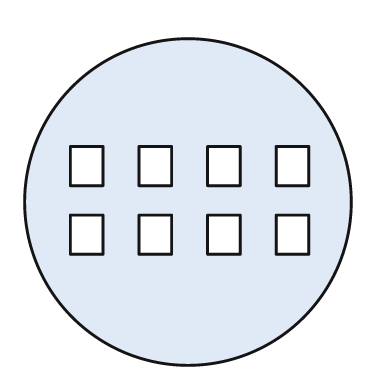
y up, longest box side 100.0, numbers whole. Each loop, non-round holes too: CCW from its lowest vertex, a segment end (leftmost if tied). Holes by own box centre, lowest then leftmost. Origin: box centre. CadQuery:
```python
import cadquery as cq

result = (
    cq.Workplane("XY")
    .moveTo(0.0, 0.0)
    .circle(50.0)
    .moveTo(-36.0, -16.0)
    .lineTo(-26.0, -16.0)
    .lineTo(-26.0, -4.0)
    .lineTo(-36.0, -4.0)
    .close()
    .moveTo(-15.0, -16.0)
    .lineTo(-5.0, -16.0)
    .lineTo(-5.0, -4.0)
    .lineTo(-15.0, -4.0)
    .close()
    .moveTo(6.0, -16.0)
    .lineTo(16.0, -16.0)
    .lineTo(16.0, -4.0)
    .lineTo(6.0, -4.0)
    .close()
    .moveTo(27.0, -16.0)
    .lineTo(37.0, -16.0)
    .lineTo(37.0, -4.0)
    .lineTo(27.0, -4.0)
    .close()
    .moveTo(-36.0, 5.0)
    .lineTo(-26.0, 5.0)
    .lineTo(-26.0, 17.0)
    .lineTo(-36.0, 17.0)
    .close()
    .moveTo(-15.0, 5.0)
    .lineTo(-5.0, 5.0)
    .lineTo(-5.0, 17.0)
    .lineTo(-15.0, 17.0)
    .close()
    .moveTo(6.0, 5.0)
    .lineTo(16.0, 5.0)
    .lineTo(16.0, 17.0)
    .lineTo(6.0, 17.0)
    .close()
    .moveTo(27.0, 5.0)
    .lineTo(37.0, 5.0)
    .lineTo(37.0, 17.0)
    .lineTo(27.0, 17.0)
    .close()
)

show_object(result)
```